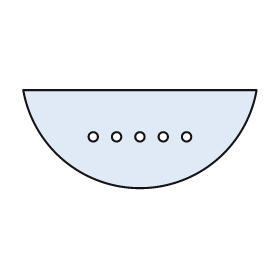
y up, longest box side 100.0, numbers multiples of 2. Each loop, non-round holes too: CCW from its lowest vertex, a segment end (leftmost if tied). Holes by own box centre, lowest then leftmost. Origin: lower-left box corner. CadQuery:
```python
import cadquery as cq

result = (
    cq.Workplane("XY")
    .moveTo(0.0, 42.0)
    .threePointArc((50.0, 0.0), (100.0, 42.0))
    .close()
    .moveTo(30.0, 22.0)
    .circle(2.0)
    .moveTo(40.0, 22.0)
    .circle(2.0)
    .moveTo(50.0, 22.0)
    .circle(2.0)
    .moveTo(60.0, 22.0)
    .circle(2.0)
    .moveTo(70.0, 22.0)
    .circle(2.0)
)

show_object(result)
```